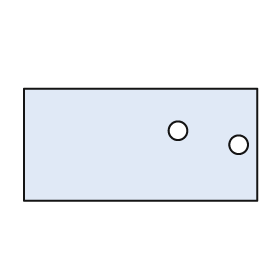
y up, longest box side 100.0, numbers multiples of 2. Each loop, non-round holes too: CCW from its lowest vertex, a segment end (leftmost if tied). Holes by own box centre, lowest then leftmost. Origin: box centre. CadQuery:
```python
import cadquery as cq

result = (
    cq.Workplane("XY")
    .moveTo(-50.0, -24.0)
    .lineTo(50.0, -24.0)
    .lineTo(50.0, 24.0)
    .lineTo(-50.0, 24.0)
    .close()
    .moveTo(42.0, 0.0)
    .circle(4.0)
    .moveTo(16.0, 6.0)
    .circle(4.0)
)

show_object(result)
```